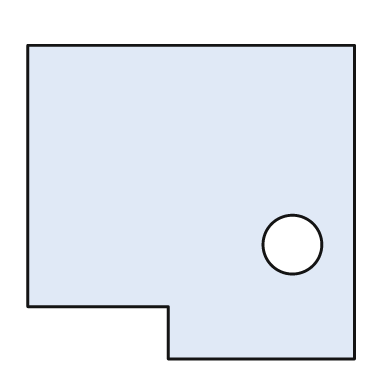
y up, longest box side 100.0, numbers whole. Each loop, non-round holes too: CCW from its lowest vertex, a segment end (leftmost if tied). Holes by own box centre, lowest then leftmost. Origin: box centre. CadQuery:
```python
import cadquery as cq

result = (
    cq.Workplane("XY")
    .moveTo(-7.0, -48.0)
    .lineTo(50.0, -48.0)
    .lineTo(50.0, 48.0)
    .lineTo(-50.0, 48.0)
    .lineTo(-50.0, -32.0)
    .lineTo(-7.0, -32.0)
    .close()
    .moveTo(31.0, -13.0)
    .circle(9.0)
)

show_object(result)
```